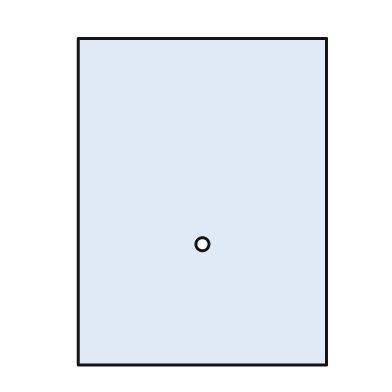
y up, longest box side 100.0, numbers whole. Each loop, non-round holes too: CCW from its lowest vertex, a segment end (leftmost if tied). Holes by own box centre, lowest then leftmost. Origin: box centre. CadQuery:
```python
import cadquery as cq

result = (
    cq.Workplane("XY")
    .moveTo(-38.0, -50.0)
    .lineTo(38.0, -50.0)
    .lineTo(38.0, 50.0)
    .lineTo(-38.0, 50.0)
    .close()
    .moveTo(0.0, -13.0)
    .circle(2.0)
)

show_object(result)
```